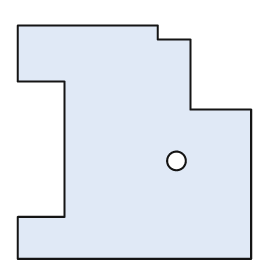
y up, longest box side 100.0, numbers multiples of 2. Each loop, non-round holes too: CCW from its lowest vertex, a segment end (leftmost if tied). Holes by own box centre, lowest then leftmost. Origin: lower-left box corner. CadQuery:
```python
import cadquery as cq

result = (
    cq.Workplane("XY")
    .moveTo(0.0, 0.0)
    .lineTo(100.0, 0.0)
    .lineTo(100.0, 64.0)
    .lineTo(74.0, 64.0)
    .lineTo(74.0, 94.0)
    .lineTo(60.0, 94.0)
    .lineTo(60.0, 100.0)
    .lineTo(0.0, 100.0)
    .lineTo(0.0, 76.0)
    .lineTo(20.0, 76.0)
    .lineTo(20.0, 18.0)
    .lineTo(0.0, 18.0)
    .close()
    .moveTo(68.0, 42.0)
    .circle(4.0)
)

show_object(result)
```